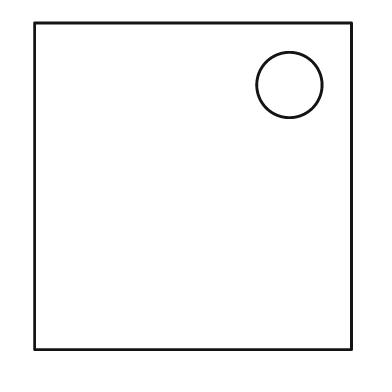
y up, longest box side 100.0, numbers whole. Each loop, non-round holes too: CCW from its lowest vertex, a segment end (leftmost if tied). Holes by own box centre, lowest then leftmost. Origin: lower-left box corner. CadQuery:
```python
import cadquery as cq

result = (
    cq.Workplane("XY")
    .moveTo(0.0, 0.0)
    .lineTo(97.0, 0.0)
    .lineTo(97.0, 100.0)
    .lineTo(0.0, 100.0)
    .close()
    .moveTo(78.0, 81.0)
    .circle(10.0)
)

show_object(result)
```